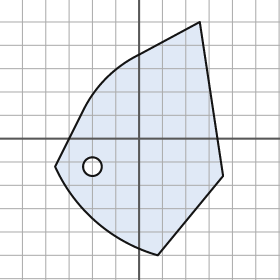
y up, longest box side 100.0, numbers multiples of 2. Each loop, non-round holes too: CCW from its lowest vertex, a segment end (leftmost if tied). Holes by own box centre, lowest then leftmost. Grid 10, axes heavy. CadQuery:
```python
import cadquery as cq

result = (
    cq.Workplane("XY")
    .moveTo(8.0, -50.0)
    .lineTo(36.0, -16.0)
    .lineTo(26.0, 50.0)
    .lineTo(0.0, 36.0)
    .threePointArc((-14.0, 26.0), (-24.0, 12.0))
    .lineTo(-36.0, -12.0)
    .threePointArc((-18.0, -36.0), (8.0, -50.0))
    .close()
    .moveTo(-20.0, -12.0)
    .circle(4.0)
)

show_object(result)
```